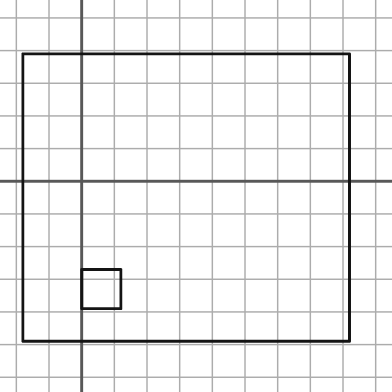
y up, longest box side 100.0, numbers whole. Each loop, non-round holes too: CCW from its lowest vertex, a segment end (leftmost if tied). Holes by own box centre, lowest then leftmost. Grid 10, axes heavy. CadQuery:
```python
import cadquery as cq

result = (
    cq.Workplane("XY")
    .moveTo(-18.0, -49.0)
    .lineTo(82.0, -49.0)
    .lineTo(82.0, 39.0)
    .lineTo(-18.0, 39.0)
    .close()
    .moveTo(0.0, -39.0)
    .lineTo(12.0, -39.0)
    .lineTo(12.0, -27.0)
    .lineTo(0.0, -27.0)
    .close()
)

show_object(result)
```